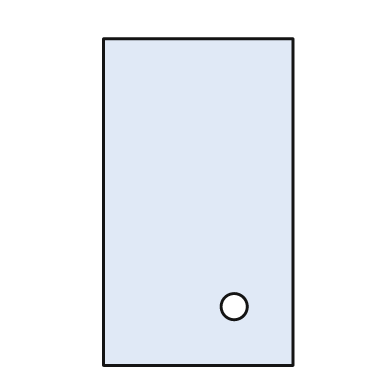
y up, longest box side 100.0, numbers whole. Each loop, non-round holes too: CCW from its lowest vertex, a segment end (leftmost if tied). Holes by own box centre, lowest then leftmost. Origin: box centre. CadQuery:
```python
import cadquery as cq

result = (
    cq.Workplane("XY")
    .moveTo(-29.0, -50.0)
    .lineTo(29.0, -50.0)
    .lineTo(29.0, 50.0)
    .lineTo(-29.0, 50.0)
    .close()
    .moveTo(11.0, -32.0)
    .circle(4.0)
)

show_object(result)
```